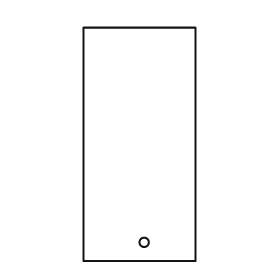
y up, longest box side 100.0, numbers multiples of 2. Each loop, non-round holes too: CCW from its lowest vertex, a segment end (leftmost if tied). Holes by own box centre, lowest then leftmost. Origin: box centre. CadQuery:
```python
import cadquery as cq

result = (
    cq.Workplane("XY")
    .moveTo(-24.0, -50.0)
    .lineTo(24.0, -50.0)
    .lineTo(24.0, 50.0)
    .lineTo(-24.0, 50.0)
    .close()
    .moveTo(2.0, -42.0)
    .circle(2.0)
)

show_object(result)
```